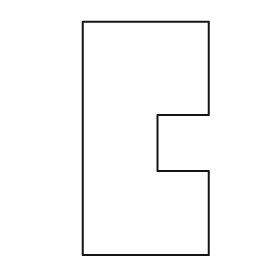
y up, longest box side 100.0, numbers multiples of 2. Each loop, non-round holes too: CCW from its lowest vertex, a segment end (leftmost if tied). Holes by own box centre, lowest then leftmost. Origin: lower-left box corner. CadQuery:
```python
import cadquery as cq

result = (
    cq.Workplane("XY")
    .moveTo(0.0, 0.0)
    .lineTo(54.0, 0.0)
    .lineTo(54.0, 36.0)
    .lineTo(32.0, 36.0)
    .lineTo(32.0, 60.0)
    .lineTo(54.0, 60.0)
    .lineTo(54.0, 100.0)
    .lineTo(0.0, 100.0)
    .close()
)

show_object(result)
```